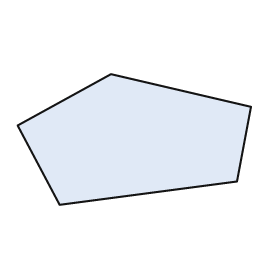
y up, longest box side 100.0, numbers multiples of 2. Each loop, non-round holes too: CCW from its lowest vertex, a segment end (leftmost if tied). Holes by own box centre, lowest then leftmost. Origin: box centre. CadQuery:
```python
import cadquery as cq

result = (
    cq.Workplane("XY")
    .moveTo(-32.0, -28.0)
    .lineTo(44.0, -18.0)
    .lineTo(50.0, 14.0)
    .lineTo(-10.0, 28.0)
    .lineTo(-50.0, 6.0)
    .close()
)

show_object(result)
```